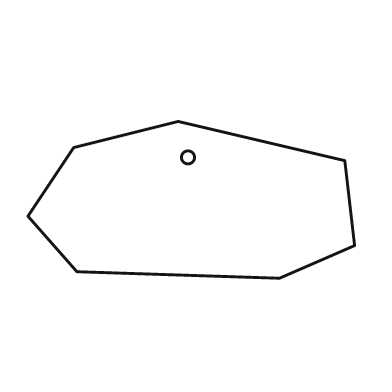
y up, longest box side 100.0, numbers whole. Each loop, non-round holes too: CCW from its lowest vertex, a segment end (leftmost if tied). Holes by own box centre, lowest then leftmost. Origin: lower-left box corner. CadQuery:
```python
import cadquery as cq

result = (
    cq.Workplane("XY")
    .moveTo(77.0, 0.0)
    .lineTo(100.0, 10.0)
    .lineTo(97.0, 36.0)
    .lineTo(46.0, 48.0)
    .lineTo(14.0, 40.0)
    .lineTo(0.0, 19.0)
    .lineTo(15.0, 2.0)
    .close()
    .moveTo(49.0, 37.0)
    .circle(2.0)
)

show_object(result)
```